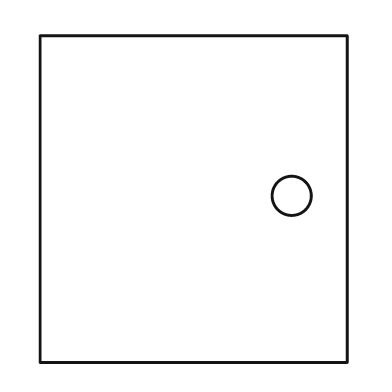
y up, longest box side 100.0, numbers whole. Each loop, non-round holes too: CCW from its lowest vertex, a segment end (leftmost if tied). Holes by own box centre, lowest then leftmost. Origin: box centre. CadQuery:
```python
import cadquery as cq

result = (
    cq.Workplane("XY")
    .moveTo(-47.0, -50.0)
    .lineTo(47.0, -50.0)
    .lineTo(47.0, 50.0)
    .lineTo(-47.0, 50.0)
    .close()
    .moveTo(30.0, 1.0)
    .circle(6.0)
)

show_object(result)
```